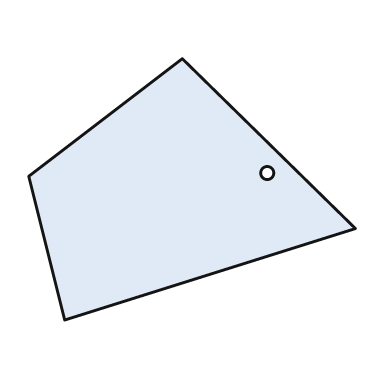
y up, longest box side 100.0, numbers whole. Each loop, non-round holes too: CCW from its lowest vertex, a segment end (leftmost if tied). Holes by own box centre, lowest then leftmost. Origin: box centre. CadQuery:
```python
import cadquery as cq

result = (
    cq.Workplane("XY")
    .moveTo(-39.0, -40.0)
    .lineTo(50.0, -12.0)
    .lineTo(-3.0, 40.0)
    .lineTo(-50.0, 4.0)
    .close()
    .moveTo(23.0, 5.0)
    .circle(2.0)
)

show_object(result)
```